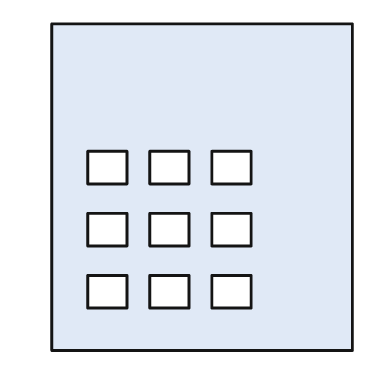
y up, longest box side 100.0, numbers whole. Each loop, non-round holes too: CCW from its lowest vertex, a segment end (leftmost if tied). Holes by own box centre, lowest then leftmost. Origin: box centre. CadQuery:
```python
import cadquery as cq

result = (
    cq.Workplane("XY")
    .moveTo(-46.0, -50.0)
    .lineTo(46.0, -50.0)
    .lineTo(46.0, 50.0)
    .lineTo(-46.0, 50.0)
    .close()
    .moveTo(-35.0, -37.0)
    .lineTo(-23.0, -37.0)
    .lineTo(-23.0, -27.0)
    .lineTo(-35.0, -27.0)
    .close()
    .moveTo(-16.0, -37.0)
    .lineTo(-4.0, -37.0)
    .lineTo(-4.0, -27.0)
    .lineTo(-16.0, -27.0)
    .close()
    .moveTo(3.0, -37.0)
    .lineTo(15.0, -37.0)
    .lineTo(15.0, -27.0)
    .lineTo(3.0, -27.0)
    .close()
    .moveTo(-35.0, -18.0)
    .lineTo(-23.0, -18.0)
    .lineTo(-23.0, -8.0)
    .lineTo(-35.0, -8.0)
    .close()
    .moveTo(-16.0, -18.0)
    .lineTo(-4.0, -18.0)
    .lineTo(-4.0, -8.0)
    .lineTo(-16.0, -8.0)
    .close()
    .moveTo(3.0, -18.0)
    .lineTo(15.0, -18.0)
    .lineTo(15.0, -8.0)
    .lineTo(3.0, -8.0)
    .close()
    .moveTo(-35.0, 1.0)
    .lineTo(-23.0, 1.0)
    .lineTo(-23.0, 11.0)
    .lineTo(-35.0, 11.0)
    .close()
    .moveTo(-16.0, 1.0)
    .lineTo(-4.0, 1.0)
    .lineTo(-4.0, 11.0)
    .lineTo(-16.0, 11.0)
    .close()
    .moveTo(3.0, 1.0)
    .lineTo(15.0, 1.0)
    .lineTo(15.0, 11.0)
    .lineTo(3.0, 11.0)
    .close()
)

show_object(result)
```